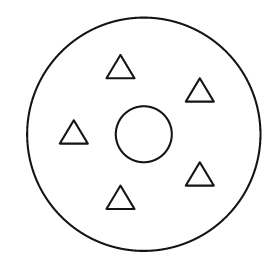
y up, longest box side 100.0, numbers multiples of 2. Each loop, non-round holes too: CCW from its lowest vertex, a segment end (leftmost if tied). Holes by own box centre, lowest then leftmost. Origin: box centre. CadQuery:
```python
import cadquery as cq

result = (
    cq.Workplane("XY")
    .moveTo(0.0, 0.0)
    .circle(50.0)
    .moveTo(-16.0, -32.0)
    .lineTo(-4.0, -32.0)
    .lineTo(-10.0, -22.0)
    .close()
    .moveTo(18.0, -22.0)
    .lineTo(30.0, -22.0)
    .lineTo(24.0, -12.0)
    .close()
    .moveTo(0.0, 0.0)
    .circle(12.0)
    .moveTo(-36.0, -4.0)
    .lineTo(-24.0, -4.0)
    .lineTo(-30.0, 6.0)
    .close()
    .moveTo(18.0, 14.0)
    .lineTo(30.0, 14.0)
    .lineTo(24.0, 24.0)
    .close()
    .moveTo(-16.0, 24.0)
    .lineTo(-4.0, 24.0)
    .lineTo(-10.0, 34.0)
    .close()
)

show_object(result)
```